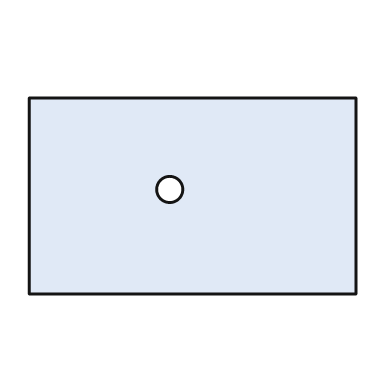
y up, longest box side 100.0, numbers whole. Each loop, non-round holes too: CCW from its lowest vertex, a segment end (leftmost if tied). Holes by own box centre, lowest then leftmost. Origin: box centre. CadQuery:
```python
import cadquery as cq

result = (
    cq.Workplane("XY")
    .moveTo(-50.0, -30.0)
    .lineTo(50.0, -30.0)
    .lineTo(50.0, 30.0)
    .lineTo(-50.0, 30.0)
    .close()
    .moveTo(-7.0, 2.0)
    .circle(4.0)
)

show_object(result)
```